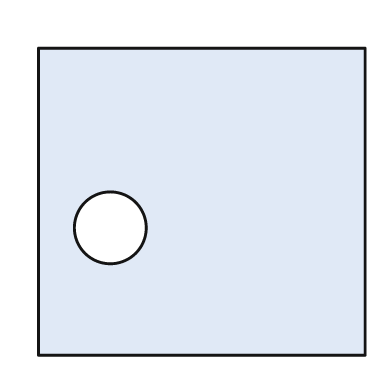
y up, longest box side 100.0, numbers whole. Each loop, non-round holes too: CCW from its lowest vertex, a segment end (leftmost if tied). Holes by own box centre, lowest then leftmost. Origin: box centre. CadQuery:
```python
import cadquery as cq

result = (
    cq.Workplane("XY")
    .moveTo(-50.0, -47.0)
    .lineTo(50.0, -47.0)
    .lineTo(50.0, 47.0)
    .lineTo(-50.0, 47.0)
    .close()
    .moveTo(-28.0, -8.0)
    .circle(11.0)
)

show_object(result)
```